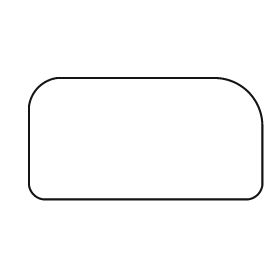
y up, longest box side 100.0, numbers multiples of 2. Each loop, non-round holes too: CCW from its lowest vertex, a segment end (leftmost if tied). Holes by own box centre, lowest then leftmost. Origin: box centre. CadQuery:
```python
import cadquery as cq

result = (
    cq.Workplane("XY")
    .moveTo(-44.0, -26.0)
    .lineTo(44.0, -26.0)
    .threePointArc((48.0, -24.0), (50.0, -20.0))
    .lineTo(50.0, 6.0)
    .threePointArc((44.0, 20.0), (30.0, 26.0))
    .lineTo(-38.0, 26.0)
    .threePointArc((-46.0, 22.0), (-50.0, 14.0))
    .lineTo(-50.0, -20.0)
    .threePointArc((-48.0, -24.0), (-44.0, -26.0))
    .close()
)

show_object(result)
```